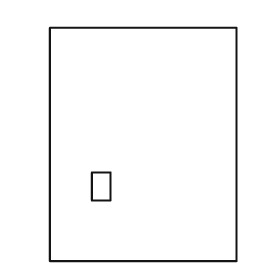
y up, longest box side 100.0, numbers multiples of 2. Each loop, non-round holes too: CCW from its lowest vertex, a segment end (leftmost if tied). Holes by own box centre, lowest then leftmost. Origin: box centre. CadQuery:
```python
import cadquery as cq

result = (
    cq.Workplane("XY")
    .moveTo(-40.0, -50.0)
    .lineTo(40.0, -50.0)
    .lineTo(40.0, 50.0)
    .lineTo(-40.0, 50.0)
    .close()
    .moveTo(-22.0, -24.0)
    .lineTo(-14.0, -24.0)
    .lineTo(-14.0, -12.0)
    .lineTo(-22.0, -12.0)
    .close()
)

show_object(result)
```